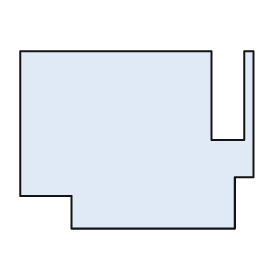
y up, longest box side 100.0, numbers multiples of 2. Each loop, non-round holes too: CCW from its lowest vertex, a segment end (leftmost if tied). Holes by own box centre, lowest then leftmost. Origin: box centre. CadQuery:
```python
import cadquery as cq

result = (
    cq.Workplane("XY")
    .moveTo(-28.0, -38.0)
    .lineTo(42.0, -38.0)
    .lineTo(42.0, -16.0)
    .lineTo(50.0, -16.0)
    .lineTo(50.0, 38.0)
    .lineTo(46.0, 38.0)
    .lineTo(46.0, 0.0)
    .lineTo(32.0, 0.0)
    .lineTo(32.0, 38.0)
    .lineTo(-50.0, 38.0)
    .lineTo(-50.0, -24.0)
    .lineTo(-28.0, -24.0)
    .close()
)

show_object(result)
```